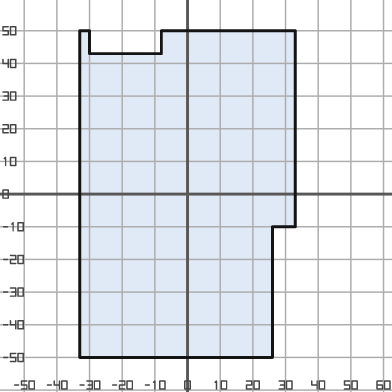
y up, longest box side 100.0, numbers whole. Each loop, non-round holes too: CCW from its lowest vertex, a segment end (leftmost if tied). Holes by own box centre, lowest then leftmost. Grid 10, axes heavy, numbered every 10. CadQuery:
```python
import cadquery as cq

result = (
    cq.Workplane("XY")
    .moveTo(-33.0, -50.0)
    .lineTo(26.0, -50.0)
    .lineTo(26.0, -10.0)
    .lineTo(33.0, -10.0)
    .lineTo(33.0, 50.0)
    .lineTo(-8.0, 50.0)
    .lineTo(-8.0, 43.0)
    .lineTo(-30.0, 43.0)
    .lineTo(-30.0, 50.0)
    .lineTo(-33.0, 50.0)
    .close()
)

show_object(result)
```